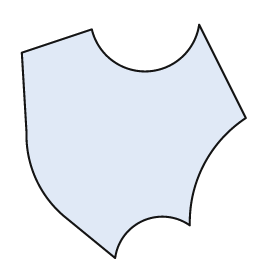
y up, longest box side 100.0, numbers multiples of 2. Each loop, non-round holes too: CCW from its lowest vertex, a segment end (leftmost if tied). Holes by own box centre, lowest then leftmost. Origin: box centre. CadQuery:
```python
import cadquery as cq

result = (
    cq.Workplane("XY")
    .moveTo(-8.0, -50.0)
    .threePointArc((4.0, -34.0), (24.0, -36.0))
    .threePointArc((30.0, -10.0), (48.0, 10.0))
    .lineTo(28.0, 50.0)
    .threePointArc((6.0, 30.0), (-18.0, 48.0))
    .lineTo(-48.0, 38.0)
    .lineTo(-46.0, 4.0)
    .threePointArc((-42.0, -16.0), (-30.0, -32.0))
    .close()
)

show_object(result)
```